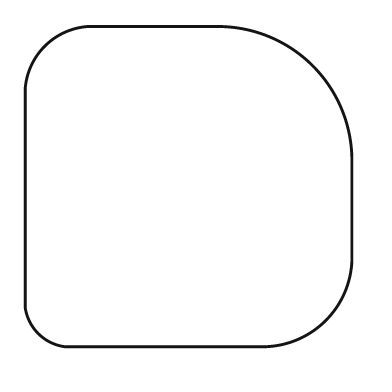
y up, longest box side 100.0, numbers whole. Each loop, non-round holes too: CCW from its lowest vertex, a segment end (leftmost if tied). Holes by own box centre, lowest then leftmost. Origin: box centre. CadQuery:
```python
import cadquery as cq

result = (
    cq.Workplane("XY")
    .moveTo(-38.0, -49.0)
    .lineTo(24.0, -49.0)
    .threePointArc((42.0, -41.0), (50.0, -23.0))
    .lineTo(50.0, 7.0)
    .threePointArc((38.0, 37.0), (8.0, 49.0))
    .lineTo(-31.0, 49.0)
    .threePointArc((-44.0, 43.0), (-50.0, 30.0))
    .lineTo(-50.0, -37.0)
    .threePointArc((-46.0, -45.0), (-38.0, -49.0))
    .close()
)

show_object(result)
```